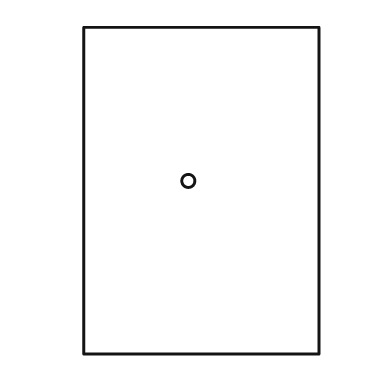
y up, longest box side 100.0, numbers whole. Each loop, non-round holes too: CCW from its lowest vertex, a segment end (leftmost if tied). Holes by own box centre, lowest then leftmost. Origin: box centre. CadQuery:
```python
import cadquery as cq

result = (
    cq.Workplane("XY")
    .moveTo(-36.0, -50.0)
    .lineTo(36.0, -50.0)
    .lineTo(36.0, 50.0)
    .lineTo(-36.0, 50.0)
    .close()
    .moveTo(-4.0, 3.0)
    .circle(2.0)
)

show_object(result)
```